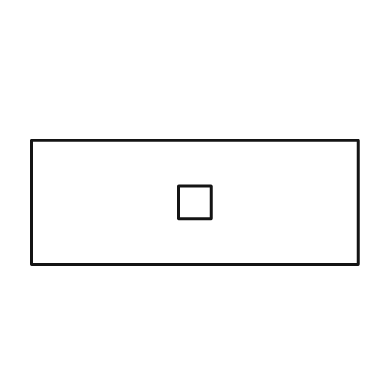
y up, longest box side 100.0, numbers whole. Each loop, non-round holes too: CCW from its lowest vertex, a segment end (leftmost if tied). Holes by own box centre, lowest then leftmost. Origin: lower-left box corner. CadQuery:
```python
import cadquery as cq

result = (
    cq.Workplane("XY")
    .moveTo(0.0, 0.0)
    .lineTo(100.0, 0.0)
    .lineTo(100.0, 38.0)
    .lineTo(0.0, 38.0)
    .close()
    .moveTo(45.0, 14.0)
    .lineTo(55.0, 14.0)
    .lineTo(55.0, 24.0)
    .lineTo(45.0, 24.0)
    .close()
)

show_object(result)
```